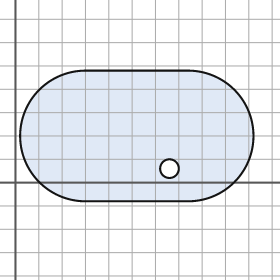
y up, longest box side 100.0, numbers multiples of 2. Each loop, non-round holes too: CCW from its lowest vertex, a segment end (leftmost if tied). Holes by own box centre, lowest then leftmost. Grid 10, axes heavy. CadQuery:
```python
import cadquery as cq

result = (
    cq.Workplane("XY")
    .moveTo(30.0, -8.0)
    .lineTo(74.0, -8.0)
    .threePointArc((102.0, 20.0), (74.0, 48.0))
    .lineTo(30.0, 48.0)
    .threePointArc((2.0, 20.0), (30.0, -8.0))
    .close()
    .moveTo(66.0, 6.0)
    .circle(4.0)
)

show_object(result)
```